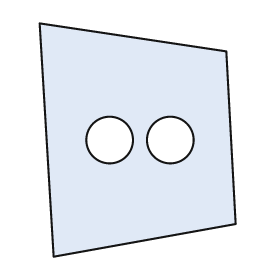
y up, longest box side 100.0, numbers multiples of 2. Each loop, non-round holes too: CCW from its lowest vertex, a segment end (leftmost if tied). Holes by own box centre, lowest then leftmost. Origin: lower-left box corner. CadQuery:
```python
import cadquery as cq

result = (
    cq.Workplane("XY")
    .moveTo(6.0, 0.0)
    .lineTo(84.0, 14.0)
    .lineTo(80.0, 88.0)
    .lineTo(0.0, 100.0)
    .close()
    .moveTo(30.0, 50.0)
    .circle(10.0)
    .moveTo(56.0, 50.0)
    .circle(10.0)
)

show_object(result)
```